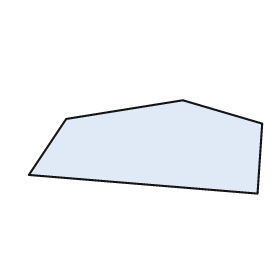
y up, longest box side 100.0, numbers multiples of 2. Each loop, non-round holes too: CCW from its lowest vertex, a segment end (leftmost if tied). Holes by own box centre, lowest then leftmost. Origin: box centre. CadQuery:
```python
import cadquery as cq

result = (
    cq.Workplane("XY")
    .moveTo(48.0, -20.0)
    .lineTo(50.0, 10.0)
    .lineTo(16.0, 20.0)
    .lineTo(-34.0, 12.0)
    .lineTo(-50.0, -12.0)
    .close()
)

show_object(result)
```